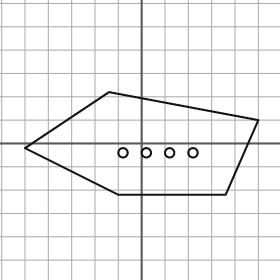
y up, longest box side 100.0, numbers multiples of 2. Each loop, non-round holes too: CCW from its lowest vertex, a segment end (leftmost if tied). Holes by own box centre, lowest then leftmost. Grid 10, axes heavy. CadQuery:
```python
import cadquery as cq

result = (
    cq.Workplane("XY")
    .moveTo(-10.0, -22.0)
    .lineTo(36.0, -22.0)
    .lineTo(50.0, 10.0)
    .lineTo(-14.0, 22.0)
    .lineTo(-50.0, -2.0)
    .close()
    .moveTo(-8.0, -4.0)
    .circle(2.0)
    .moveTo(2.0, -4.0)
    .circle(2.0)
    .moveTo(12.0, -4.0)
    .circle(2.0)
    .moveTo(22.0, -4.0)
    .circle(2.0)
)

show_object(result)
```